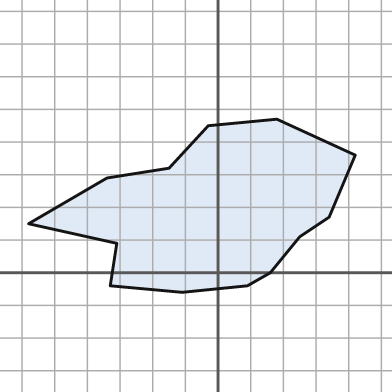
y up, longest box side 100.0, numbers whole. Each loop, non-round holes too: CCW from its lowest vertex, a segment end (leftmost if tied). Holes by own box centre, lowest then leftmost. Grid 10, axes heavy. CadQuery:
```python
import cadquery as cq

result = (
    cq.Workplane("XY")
    .moveTo(-11.0, -6.0)
    .lineTo(9.0, -4.0)
    .lineTo(16.0, 0.0)
    .lineTo(25.0, 11.0)
    .lineTo(34.0, 17.0)
    .lineTo(42.0, 36.0)
    .lineTo(18.0, 47.0)
    .lineTo(-3.0, 45.0)
    .lineTo(-15.0, 32.0)
    .lineTo(-34.0, 29.0)
    .lineTo(-58.0, 15.0)
    .lineTo(-31.0, 9.0)
    .lineTo(-33.0, -4.0)
    .close()
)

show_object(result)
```